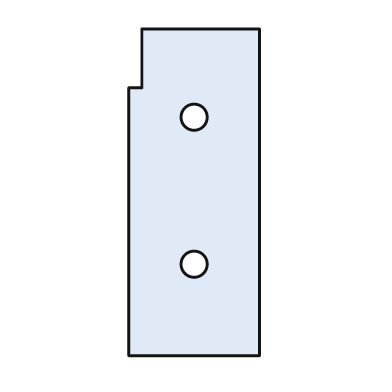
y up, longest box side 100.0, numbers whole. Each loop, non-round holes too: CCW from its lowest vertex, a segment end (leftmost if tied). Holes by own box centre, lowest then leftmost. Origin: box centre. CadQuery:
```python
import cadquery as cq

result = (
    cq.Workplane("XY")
    .moveTo(-20.0, -50.0)
    .lineTo(20.0, -50.0)
    .lineTo(20.0, 50.0)
    .lineTo(-16.0, 50.0)
    .lineTo(-16.0, 32.0)
    .lineTo(-20.0, 32.0)
    .close()
    .moveTo(0.0, -22.0)
    .circle(4.0)
    .moveTo(0.0, 23.0)
    .circle(4.0)
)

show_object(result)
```